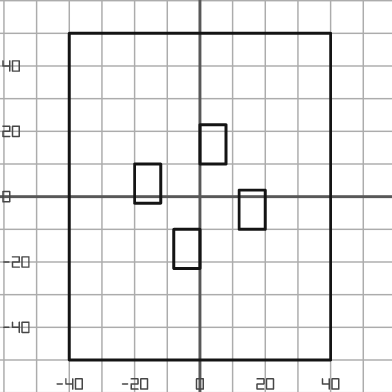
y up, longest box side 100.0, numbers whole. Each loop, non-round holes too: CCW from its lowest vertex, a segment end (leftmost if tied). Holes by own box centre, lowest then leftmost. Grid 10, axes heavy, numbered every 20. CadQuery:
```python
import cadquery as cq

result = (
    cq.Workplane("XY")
    .moveTo(-40.0, -50.0)
    .lineTo(40.0, -50.0)
    .lineTo(40.0, 50.0)
    .lineTo(-40.0, 50.0)
    .close()
    .moveTo(-8.0, -22.0)
    .lineTo(0.0, -22.0)
    .lineTo(0.0, -10.0)
    .lineTo(-8.0, -10.0)
    .close()
    .moveTo(12.0, -10.0)
    .lineTo(20.0, -10.0)
    .lineTo(20.0, 2.0)
    .lineTo(12.0, 2.0)
    .close()
    .moveTo(-20.0, -2.0)
    .lineTo(-12.0, -2.0)
    .lineTo(-12.0, 10.0)
    .lineTo(-20.0, 10.0)
    .close()
    .moveTo(0.0, 10.0)
    .lineTo(8.0, 10.0)
    .lineTo(8.0, 22.0)
    .lineTo(0.0, 22.0)
    .close()
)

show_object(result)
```